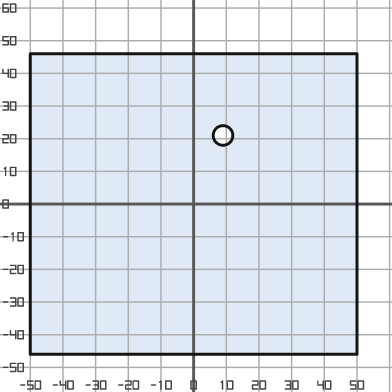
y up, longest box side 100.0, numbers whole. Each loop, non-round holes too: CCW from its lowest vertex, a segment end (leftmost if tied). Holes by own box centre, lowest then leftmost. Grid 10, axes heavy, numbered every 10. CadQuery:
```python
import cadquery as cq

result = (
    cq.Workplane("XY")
    .moveTo(-50.0, -46.0)
    .lineTo(50.0, -46.0)
    .lineTo(50.0, 46.0)
    .lineTo(-50.0, 46.0)
    .close()
    .moveTo(9.0, 21.0)
    .circle(3.0)
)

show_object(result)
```